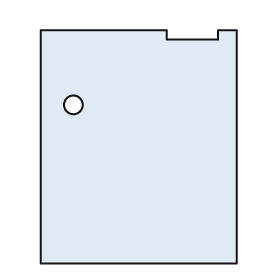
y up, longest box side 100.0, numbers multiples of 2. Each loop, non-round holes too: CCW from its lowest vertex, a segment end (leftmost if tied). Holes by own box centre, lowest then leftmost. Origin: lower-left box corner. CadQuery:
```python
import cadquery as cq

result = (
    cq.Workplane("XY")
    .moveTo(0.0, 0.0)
    .lineTo(84.0, 0.0)
    .lineTo(84.0, 100.0)
    .lineTo(76.0, 100.0)
    .lineTo(76.0, 96.0)
    .lineTo(54.0, 96.0)
    .lineTo(54.0, 100.0)
    .lineTo(0.0, 100.0)
    .close()
    .moveTo(14.0, 68.0)
    .circle(4.0)
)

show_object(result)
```